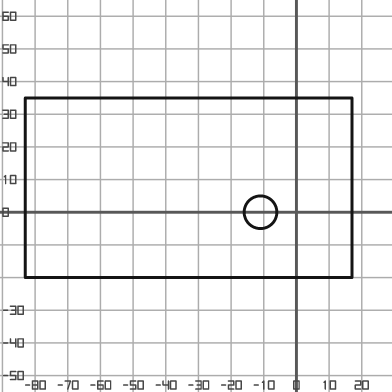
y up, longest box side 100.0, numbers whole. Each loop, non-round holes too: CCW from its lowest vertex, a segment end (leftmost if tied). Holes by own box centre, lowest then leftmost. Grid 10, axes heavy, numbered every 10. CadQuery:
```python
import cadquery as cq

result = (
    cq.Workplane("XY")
    .moveTo(-83.0, -20.0)
    .lineTo(17.0, -20.0)
    .lineTo(17.0, 35.0)
    .lineTo(-83.0, 35.0)
    .close()
    .moveTo(-11.0, 0.0)
    .circle(5.0)
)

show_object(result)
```